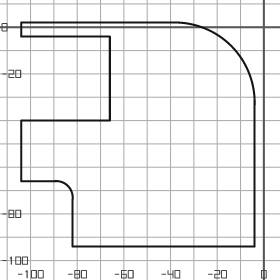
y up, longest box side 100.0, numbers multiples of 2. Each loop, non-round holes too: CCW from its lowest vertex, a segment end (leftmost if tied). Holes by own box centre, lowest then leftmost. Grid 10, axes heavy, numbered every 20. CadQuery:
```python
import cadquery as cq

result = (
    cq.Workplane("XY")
    .moveTo(-82.0, -94.0)
    .lineTo(-4.0, -94.0)
    .lineTo(-4.0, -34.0)
    .threePointArc((-14.0, -8.0), (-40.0, 2.0))
    .lineTo(-104.0, 2.0)
    .lineTo(-104.0, -4.0)
    .lineTo(-66.0, -4.0)
    .lineTo(-66.0, -40.0)
    .lineTo(-104.0, -40.0)
    .lineTo(-104.0, -66.0)
    .lineTo(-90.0, -66.0)
    .threePointArc((-84.0, -68.0), (-82.0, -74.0))
    .close()
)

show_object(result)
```